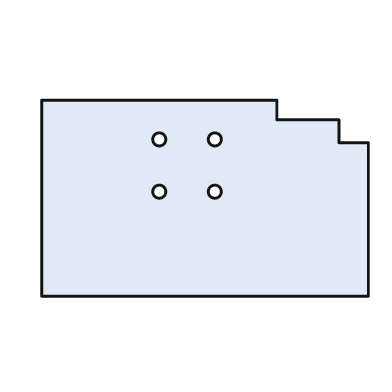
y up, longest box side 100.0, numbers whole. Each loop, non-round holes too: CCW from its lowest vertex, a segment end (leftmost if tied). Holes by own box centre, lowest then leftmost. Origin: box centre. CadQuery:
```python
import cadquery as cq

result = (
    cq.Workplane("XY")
    .moveTo(-50.0, -30.0)
    .lineTo(50.0, -30.0)
    .lineTo(50.0, 17.0)
    .lineTo(41.0, 17.0)
    .lineTo(41.0, 24.0)
    .lineTo(22.0, 24.0)
    .lineTo(22.0, 30.0)
    .lineTo(-50.0, 30.0)
    .close()
    .moveTo(-14.0, 2.0)
    .circle(2.0)
    .moveTo(3.0, 2.0)
    .circle(2.0)
    .moveTo(-14.0, 18.0)
    .circle(2.0)
    .moveTo(3.0, 18.0)
    .circle(2.0)
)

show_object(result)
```